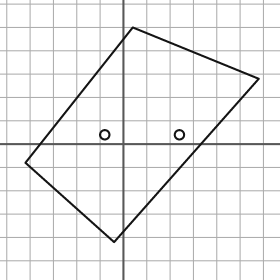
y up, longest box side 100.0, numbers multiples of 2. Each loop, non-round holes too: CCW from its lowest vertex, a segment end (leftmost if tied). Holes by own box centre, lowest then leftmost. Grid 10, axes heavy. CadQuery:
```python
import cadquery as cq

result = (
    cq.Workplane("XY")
    .moveTo(-4.0, -42.0)
    .lineTo(58.0, 28.0)
    .lineTo(4.0, 50.0)
    .lineTo(-42.0, -8.0)
    .close()
    .moveTo(-8.0, 4.0)
    .circle(2.0)
    .moveTo(24.0, 4.0)
    .circle(2.0)
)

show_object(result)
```